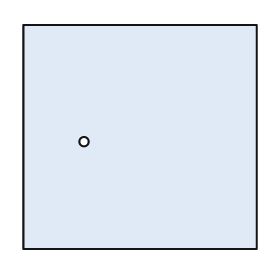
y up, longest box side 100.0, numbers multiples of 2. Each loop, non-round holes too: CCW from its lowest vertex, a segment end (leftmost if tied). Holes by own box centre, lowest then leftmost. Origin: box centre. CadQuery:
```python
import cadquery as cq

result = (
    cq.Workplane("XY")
    .moveTo(-50.0, -48.0)
    .lineTo(50.0, -48.0)
    .lineTo(50.0, 48.0)
    .lineTo(-50.0, 48.0)
    .close()
    .moveTo(-24.0, -2.0)
    .circle(2.0)
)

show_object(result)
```